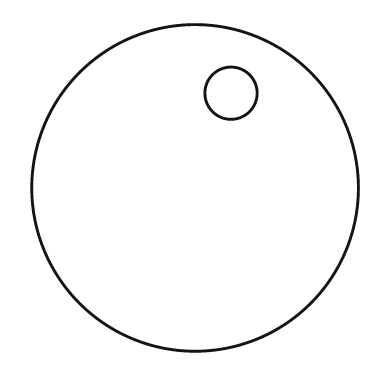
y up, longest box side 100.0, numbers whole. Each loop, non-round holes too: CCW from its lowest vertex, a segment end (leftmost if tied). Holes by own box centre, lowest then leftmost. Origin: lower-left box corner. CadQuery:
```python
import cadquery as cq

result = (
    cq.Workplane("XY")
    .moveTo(50.0, 50.0)
    .circle(50.0)
    .moveTo(61.0, 79.0)
    .circle(8.0)
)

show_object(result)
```